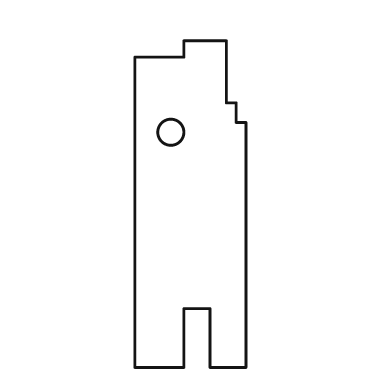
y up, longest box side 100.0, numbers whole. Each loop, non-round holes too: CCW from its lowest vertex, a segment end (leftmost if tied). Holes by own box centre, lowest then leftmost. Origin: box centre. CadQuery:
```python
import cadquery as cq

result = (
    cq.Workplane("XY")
    .moveTo(-17.0, -50.0)
    .lineTo(-2.0, -50.0)
    .lineTo(-2.0, -32.0)
    .lineTo(6.0, -32.0)
    .lineTo(6.0, -50.0)
    .lineTo(17.0, -50.0)
    .lineTo(17.0, 25.0)
    .lineTo(14.0, 25.0)
    .lineTo(14.0, 31.0)
    .lineTo(11.0, 31.0)
    .lineTo(11.0, 50.0)
    .lineTo(-2.0, 50.0)
    .lineTo(-2.0, 45.0)
    .lineTo(-17.0, 45.0)
    .close()
    .moveTo(-6.0, 22.0)
    .circle(4.0)
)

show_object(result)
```